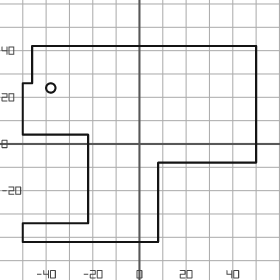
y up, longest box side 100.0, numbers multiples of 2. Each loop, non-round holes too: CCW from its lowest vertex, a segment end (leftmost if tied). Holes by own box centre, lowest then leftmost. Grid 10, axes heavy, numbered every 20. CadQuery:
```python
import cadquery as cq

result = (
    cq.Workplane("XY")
    .moveTo(-50.0, -42.0)
    .lineTo(8.0, -42.0)
    .lineTo(8.0, -8.0)
    .lineTo(50.0, -8.0)
    .lineTo(50.0, 42.0)
    .lineTo(-46.0, 42.0)
    .lineTo(-46.0, 26.0)
    .lineTo(-50.0, 26.0)
    .lineTo(-50.0, 4.0)
    .lineTo(-22.0, 4.0)
    .lineTo(-22.0, -34.0)
    .lineTo(-50.0, -34.0)
    .close()
    .moveTo(-38.0, 24.0)
    .circle(2.0)
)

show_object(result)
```